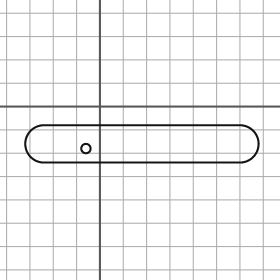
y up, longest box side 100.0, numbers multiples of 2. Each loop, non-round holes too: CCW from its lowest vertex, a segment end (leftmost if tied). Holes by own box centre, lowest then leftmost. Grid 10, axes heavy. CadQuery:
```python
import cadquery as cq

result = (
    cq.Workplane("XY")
    .moveTo(-24.0, -24.0)
    .lineTo(60.0, -24.0)
    .threePointArc((68.0, -16.0), (60.0, -8.0))
    .lineTo(-24.0, -8.0)
    .threePointArc((-32.0, -16.0), (-24.0, -24.0))
    .close()
    .moveTo(-6.0, -18.0)
    .circle(2.0)
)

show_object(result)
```